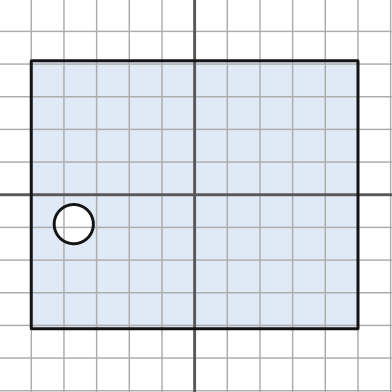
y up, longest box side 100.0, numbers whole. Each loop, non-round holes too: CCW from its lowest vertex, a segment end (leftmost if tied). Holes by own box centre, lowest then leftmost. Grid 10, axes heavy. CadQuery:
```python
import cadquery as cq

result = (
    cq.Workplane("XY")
    .moveTo(-50.0, -41.0)
    .lineTo(50.0, -41.0)
    .lineTo(50.0, 41.0)
    .lineTo(-50.0, 41.0)
    .close()
    .moveTo(-37.0, -9.0)
    .circle(6.0)
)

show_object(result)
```